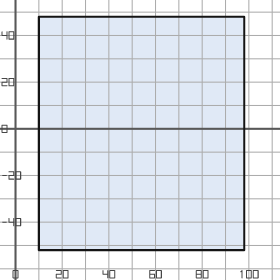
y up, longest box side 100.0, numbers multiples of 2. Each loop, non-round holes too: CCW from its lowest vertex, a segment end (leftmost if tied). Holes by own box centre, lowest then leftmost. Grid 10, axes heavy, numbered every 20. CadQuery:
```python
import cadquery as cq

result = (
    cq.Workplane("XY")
    .moveTo(10.0, -52.0)
    .lineTo(98.0, -52.0)
    .lineTo(98.0, 48.0)
    .lineTo(10.0, 48.0)
    .close()
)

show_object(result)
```